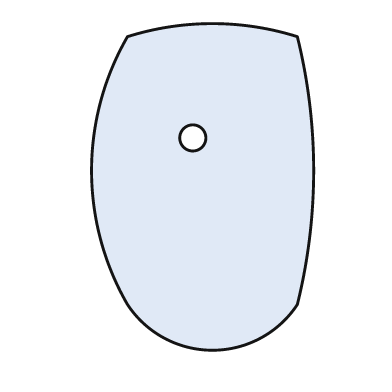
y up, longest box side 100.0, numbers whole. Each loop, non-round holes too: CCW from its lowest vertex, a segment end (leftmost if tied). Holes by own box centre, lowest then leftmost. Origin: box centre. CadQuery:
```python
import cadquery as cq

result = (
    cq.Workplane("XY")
    .moveTo(-23.0, -36.0)
    .threePointArc((3.0, -50.0), (29.0, -36.0))
    .threePointArc((34.0, 5.0), (29.0, 46.0))
    .threePointArc((3.0, 50.0), (-23.0, 46.0))
    .threePointArc((-34.0, 5.0), (-23.0, -36.0))
    .close()
    .moveTo(-3.0, 15.0)
    .circle(4.0)
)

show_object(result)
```